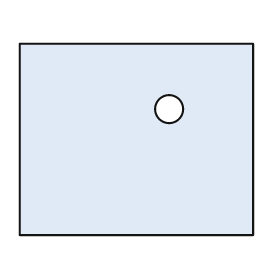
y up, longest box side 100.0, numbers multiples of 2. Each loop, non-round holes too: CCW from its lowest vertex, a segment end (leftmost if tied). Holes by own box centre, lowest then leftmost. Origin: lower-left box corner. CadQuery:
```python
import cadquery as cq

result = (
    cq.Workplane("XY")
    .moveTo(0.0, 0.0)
    .lineTo(100.0, 0.0)
    .lineTo(100.0, 82.0)
    .lineTo(0.0, 82.0)
    .close()
    .moveTo(64.0, 54.0)
    .circle(6.0)
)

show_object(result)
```